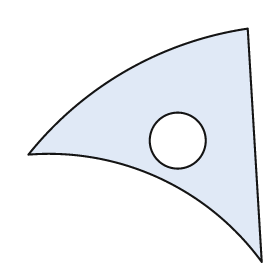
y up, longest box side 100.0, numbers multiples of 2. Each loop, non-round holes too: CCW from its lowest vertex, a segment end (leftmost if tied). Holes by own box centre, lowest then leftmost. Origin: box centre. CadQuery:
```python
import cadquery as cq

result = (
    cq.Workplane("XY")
    .moveTo(50.0, -50.0)
    .lineTo(44.0, 50.0)
    .threePointArc((-8.0, 32.0), (-50.0, -4.0))
    .threePointArc((6.0, -14.0), (50.0, -50.0))
    .close()
    .moveTo(14.0, 2.0)
    .circle(12.0)
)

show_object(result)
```